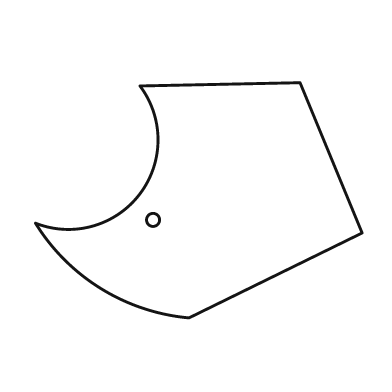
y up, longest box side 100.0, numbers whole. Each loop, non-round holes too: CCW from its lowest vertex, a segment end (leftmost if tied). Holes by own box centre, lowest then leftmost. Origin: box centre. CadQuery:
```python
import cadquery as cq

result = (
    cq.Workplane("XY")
    .moveTo(-3.0, -36.0)
    .lineTo(50.0, -10.0)
    .lineTo(31.0, 36.0)
    .lineTo(-18.0, 35.0)
    .threePointArc((-18.0, 2.0), (-50.0, -7.0))
    .threePointArc((-30.0, -27.0), (-3.0, -36.0))
    .close()
    .moveTo(-14.0, -6.0)
    .circle(2.0)
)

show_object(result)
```